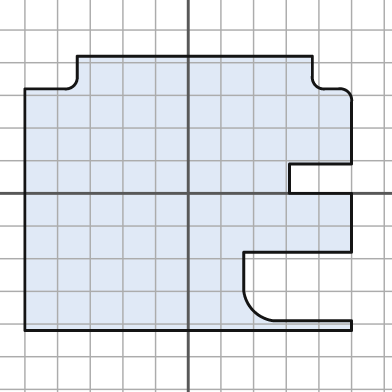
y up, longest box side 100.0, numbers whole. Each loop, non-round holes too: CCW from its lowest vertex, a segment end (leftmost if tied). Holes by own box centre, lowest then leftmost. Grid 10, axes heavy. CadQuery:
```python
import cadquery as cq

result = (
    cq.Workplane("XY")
    .moveTo(-50.0, -42.0)
    .lineTo(50.0, -42.0)
    .lineTo(50.0, -39.0)
    .lineTo(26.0, -39.0)
    .threePointArc((20.0, -36.0), (17.0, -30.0))
    .lineTo(17.0, -18.0)
    .lineTo(50.0, -18.0)
    .lineTo(50.0, 0.0)
    .lineTo(31.0, 0.0)
    .lineTo(31.0, 9.0)
    .lineTo(50.0, 9.0)
    .lineTo(50.0, 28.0)
    .threePointArc((49.0, 31.0), (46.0, 32.0))
    .lineTo(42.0, 32.0)
    .threePointArc((39.0, 33.0), (38.0, 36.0))
    .lineTo(38.0, 42.0)
    .lineTo(-34.0, 42.0)
    .lineTo(-34.0, 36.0)
    .threePointArc((-35.0, 33.0), (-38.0, 32.0))
    .lineTo(-50.0, 32.0)
    .close()
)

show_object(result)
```